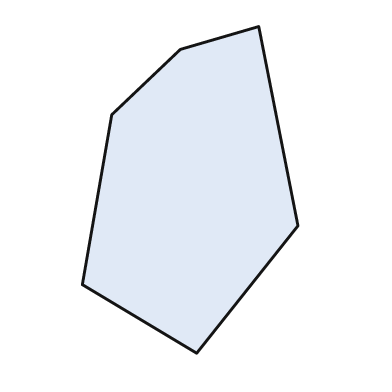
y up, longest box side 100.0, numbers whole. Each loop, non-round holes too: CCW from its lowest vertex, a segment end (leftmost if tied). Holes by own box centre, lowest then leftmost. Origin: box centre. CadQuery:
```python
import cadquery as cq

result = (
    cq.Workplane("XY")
    .moveTo(2.0, -50.0)
    .lineTo(33.0, -11.0)
    .lineTo(21.0, 50.0)
    .lineTo(-3.0, 43.0)
    .lineTo(-24.0, 23.0)
    .lineTo(-33.0, -29.0)
    .close()
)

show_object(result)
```